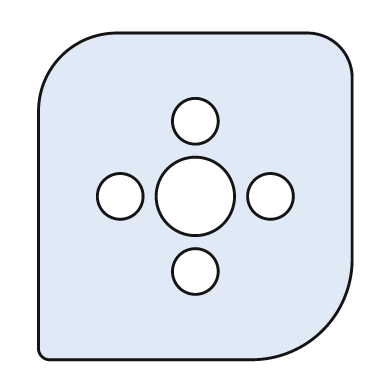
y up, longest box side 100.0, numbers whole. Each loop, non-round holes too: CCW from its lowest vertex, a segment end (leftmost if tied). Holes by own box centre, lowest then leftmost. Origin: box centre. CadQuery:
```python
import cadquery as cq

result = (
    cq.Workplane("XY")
    .moveTo(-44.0, -50.0)
    .lineTo(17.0, -50.0)
    .threePointArc((39.0, -41.0), (48.0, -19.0))
    .lineTo(48.0, 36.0)
    .threePointArc((44.0, 46.0), (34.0, 50.0))
    .lineTo(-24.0, 50.0)
    .threePointArc((-41.0, 43.0), (-48.0, 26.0))
    .lineTo(-48.0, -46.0)
    .threePointArc((-47.0, -49.0), (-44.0, -50.0))
    .close()
    .moveTo(0.0, -23.0)
    .circle(7.0)
    .moveTo(-23.0, 0.0)
    .circle(7.0)
    .moveTo(0.0, 0.0)
    .circle(12.0)
    .moveTo(23.0, 0.0)
    .circle(7.0)
    .moveTo(0.0, 23.0)
    .circle(7.0)
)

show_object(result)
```